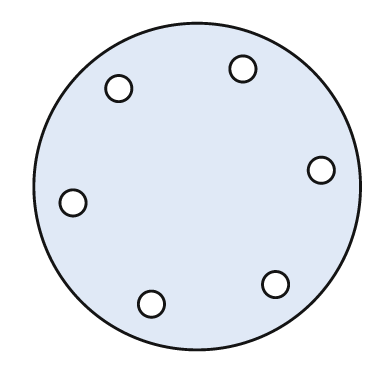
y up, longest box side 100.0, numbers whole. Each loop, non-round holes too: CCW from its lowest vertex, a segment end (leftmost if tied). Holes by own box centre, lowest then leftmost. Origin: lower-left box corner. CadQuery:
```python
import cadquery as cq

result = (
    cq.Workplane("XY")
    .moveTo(50.0, 50.0)
    .circle(50.0)
    .moveTo(36.0, 14.0)
    .circle(4.0)
    .moveTo(74.0, 20.0)
    .circle(4.0)
    .moveTo(12.0, 45.0)
    .circle(4.0)
    .moveTo(88.0, 55.0)
    .circle(4.0)
    .moveTo(26.0, 80.0)
    .circle(4.0)
    .moveTo(64.0, 86.0)
    .circle(4.0)
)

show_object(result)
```